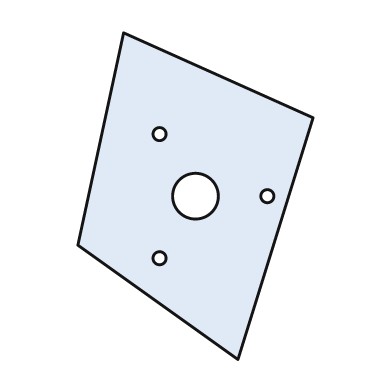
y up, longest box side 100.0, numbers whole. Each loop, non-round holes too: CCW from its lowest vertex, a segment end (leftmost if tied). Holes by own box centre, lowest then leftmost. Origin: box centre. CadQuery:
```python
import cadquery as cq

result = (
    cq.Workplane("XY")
    .moveTo(13.0, -50.0)
    .lineTo(36.0, 24.0)
    .lineTo(-22.0, 50.0)
    .lineTo(-36.0, -15.0)
    .close()
    .moveTo(-11.0, -19.0)
    .circle(2.0)
    .moveTo(0.0, 0.0)
    .circle(7.0)
    .moveTo(22.0, 0.0)
    .circle(2.0)
    .moveTo(-11.0, 19.0)
    .circle(2.0)
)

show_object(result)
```